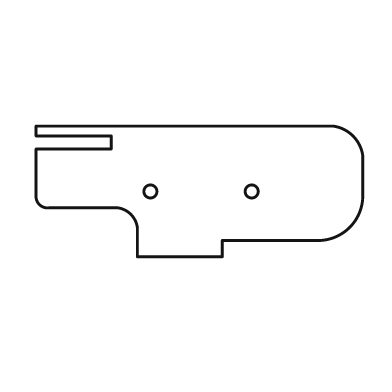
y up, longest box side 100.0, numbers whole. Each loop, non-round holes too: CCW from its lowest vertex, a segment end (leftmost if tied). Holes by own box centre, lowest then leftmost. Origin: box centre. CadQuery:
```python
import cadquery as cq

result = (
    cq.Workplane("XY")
    .moveTo(-19.0, -20.0)
    .lineTo(7.0, -20.0)
    .lineTo(7.0, -15.0)
    .lineTo(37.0, -15.0)
    .threePointArc((46.0, -11.0), (50.0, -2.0))
    .lineTo(50.0, 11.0)
    .threePointArc((47.0, 17.0), (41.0, 20.0))
    .lineTo(-50.0, 20.0)
    .lineTo(-50.0, 17.0)
    .lineTo(-27.0, 17.0)
    .lineTo(-27.0, 13.0)
    .lineTo(-50.0, 13.0)
    .lineTo(-50.0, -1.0)
    .threePointArc((-49.0, -4.0), (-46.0, -5.0))
    .lineTo(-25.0, -5.0)
    .threePointArc((-21.0, -7.0), (-19.0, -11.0))
    .close()
    .moveTo(-15.0, 0.0)
    .circle(2.0)
    .moveTo(16.0, 0.0)
    .circle(2.0)
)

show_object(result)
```